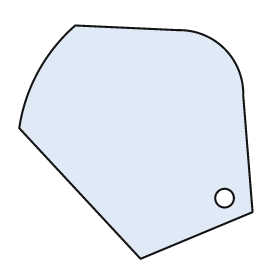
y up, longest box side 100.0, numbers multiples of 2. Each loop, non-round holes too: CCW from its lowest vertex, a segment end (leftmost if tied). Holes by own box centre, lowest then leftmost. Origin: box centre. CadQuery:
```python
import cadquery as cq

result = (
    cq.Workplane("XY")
    .moveTo(2.0, -50.0)
    .lineTo(50.0, -30.0)
    .lineTo(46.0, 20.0)
    .threePointArc((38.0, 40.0), (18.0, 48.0))
    .lineTo(-26.0, 50.0)
    .threePointArc((-42.0, 30.0), (-50.0, 6.0))
    .close()
    .moveTo(38.0, -24.0)
    .circle(4.0)
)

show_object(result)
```